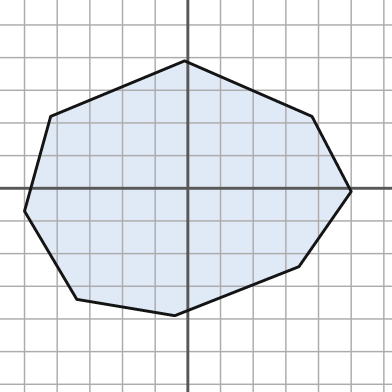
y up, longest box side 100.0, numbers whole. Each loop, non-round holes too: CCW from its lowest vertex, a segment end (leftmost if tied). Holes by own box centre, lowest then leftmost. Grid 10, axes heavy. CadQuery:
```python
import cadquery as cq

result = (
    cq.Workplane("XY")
    .moveTo(-4.0, -39.0)
    .lineTo(34.0, -24.0)
    .lineTo(50.0, -1.0)
    .lineTo(38.0, 22.0)
    .lineTo(-1.0, 39.0)
    .lineTo(-42.0, 22.0)
    .lineTo(-50.0, -7.0)
    .lineTo(-34.0, -34.0)
    .close()
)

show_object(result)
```